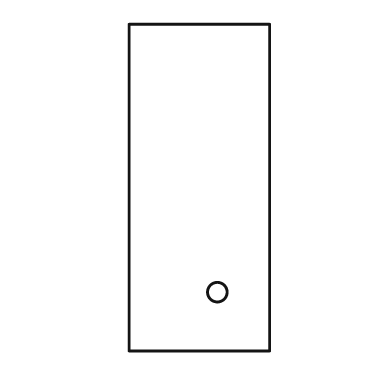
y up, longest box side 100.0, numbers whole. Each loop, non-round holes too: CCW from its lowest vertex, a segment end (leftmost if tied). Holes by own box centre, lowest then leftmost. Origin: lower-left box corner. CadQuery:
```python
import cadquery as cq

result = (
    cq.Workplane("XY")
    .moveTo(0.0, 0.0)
    .lineTo(43.0, 0.0)
    .lineTo(43.0, 100.0)
    .lineTo(0.0, 100.0)
    .close()
    .moveTo(27.0, 18.0)
    .circle(3.0)
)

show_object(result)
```